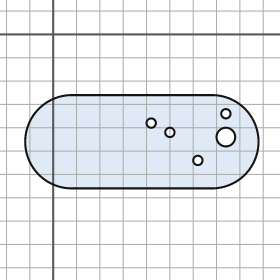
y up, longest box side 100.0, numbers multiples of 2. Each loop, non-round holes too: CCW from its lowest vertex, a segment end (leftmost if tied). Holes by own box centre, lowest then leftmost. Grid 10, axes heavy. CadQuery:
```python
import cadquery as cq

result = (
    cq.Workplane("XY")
    .moveTo(8.0, -66.0)
    .lineTo(68.0, -66.0)
    .threePointArc((88.0, -46.0), (68.0, -26.0))
    .lineTo(8.0, -26.0)
    .threePointArc((-12.0, -46.0), (8.0, -66.0))
    .close()
    .moveTo(62.0, -54.0)
    .circle(2.0)
    .moveTo(74.0, -44.0)
    .circle(4.0)
    .moveTo(50.0, -42.0)
    .circle(2.0)
    .moveTo(42.0, -38.0)
    .circle(2.0)
    .moveTo(74.0, -34.0)
    .circle(2.0)
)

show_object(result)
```